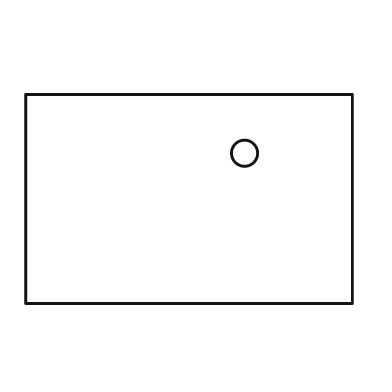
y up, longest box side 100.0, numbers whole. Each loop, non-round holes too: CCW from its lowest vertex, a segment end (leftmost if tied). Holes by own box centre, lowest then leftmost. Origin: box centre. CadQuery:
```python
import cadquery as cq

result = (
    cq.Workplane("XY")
    .moveTo(-50.0, -32.0)
    .lineTo(50.0, -32.0)
    .lineTo(50.0, 32.0)
    .lineTo(-50.0, 32.0)
    .close()
    .moveTo(17.0, 14.0)
    .circle(4.0)
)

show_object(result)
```